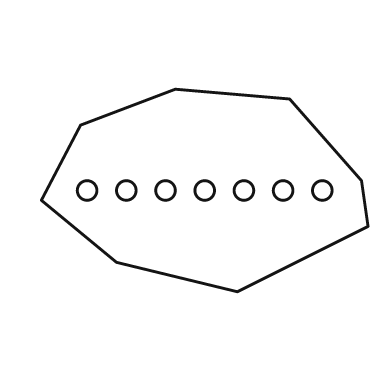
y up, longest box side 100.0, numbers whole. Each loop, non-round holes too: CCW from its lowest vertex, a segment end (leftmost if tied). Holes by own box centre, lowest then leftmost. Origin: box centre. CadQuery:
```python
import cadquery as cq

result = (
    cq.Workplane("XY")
    .moveTo(10.0, -31.0)
    .lineTo(50.0, -11.0)
    .lineTo(48.0, 3.0)
    .lineTo(26.0, 28.0)
    .lineTo(-9.0, 31.0)
    .lineTo(-38.0, 20.0)
    .lineTo(-50.0, -3.0)
    .lineTo(-27.0, -22.0)
    .close()
    .moveTo(-36.0, 0.0)
    .circle(3.0)
    .moveTo(-24.0, 0.0)
    .circle(3.0)
    .moveTo(-12.0, 0.0)
    .circle(3.0)
    .moveTo(0.0, 0.0)
    .circle(3.0)
    .moveTo(12.0, 0.0)
    .circle(3.0)
    .moveTo(24.0, 0.0)
    .circle(3.0)
    .moveTo(36.0, 0.0)
    .circle(3.0)
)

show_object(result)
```